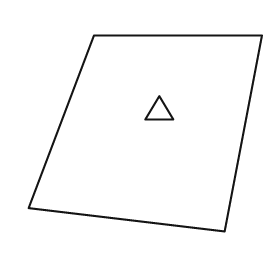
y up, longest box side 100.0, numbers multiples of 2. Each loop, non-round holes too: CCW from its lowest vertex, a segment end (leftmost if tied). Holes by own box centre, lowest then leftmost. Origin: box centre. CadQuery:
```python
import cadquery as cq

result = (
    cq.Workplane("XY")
    .moveTo(34.0, -42.0)
    .lineTo(50.0, 42.0)
    .lineTo(-22.0, 42.0)
    .lineTo(-50.0, -32.0)
    .close()
    .moveTo(0.0, 6.0)
    .lineTo(12.0, 6.0)
    .lineTo(6.0, 16.0)
    .close()
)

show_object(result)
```